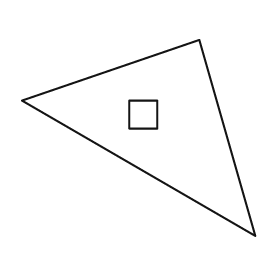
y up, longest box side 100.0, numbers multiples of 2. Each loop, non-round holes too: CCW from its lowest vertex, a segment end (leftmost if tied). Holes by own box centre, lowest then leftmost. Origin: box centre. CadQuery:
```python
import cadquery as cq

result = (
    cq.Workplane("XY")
    .moveTo(50.0, -42.0)
    .lineTo(26.0, 42.0)
    .lineTo(-50.0, 16.0)
    .close()
    .moveTo(-4.0, 4.0)
    .lineTo(8.0, 4.0)
    .lineTo(8.0, 16.0)
    .lineTo(-4.0, 16.0)
    .close()
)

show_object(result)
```